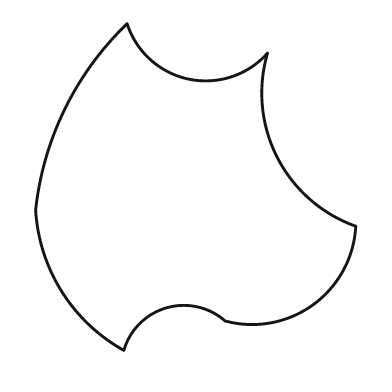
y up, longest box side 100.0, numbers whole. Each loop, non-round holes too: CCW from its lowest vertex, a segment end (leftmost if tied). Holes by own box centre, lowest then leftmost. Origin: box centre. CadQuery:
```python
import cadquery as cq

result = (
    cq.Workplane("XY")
    .moveTo(-22.0, -50.0)
    .threePointArc((-9.0, -37.0), (9.0, -41.0))
    .threePointArc((36.0, -36.0), (49.0, -12.0))
    .threePointArc((25.0, 9.0), (22.0, 41.0))
    .threePointArc((-2.0, 33.0), (-21.0, 50.0))
    .threePointArc((-40.0, 24.0), (-49.0, -7.0))
    .threePointArc((-41.0, -32.0), (-22.0, -50.0))
    .close()
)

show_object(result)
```